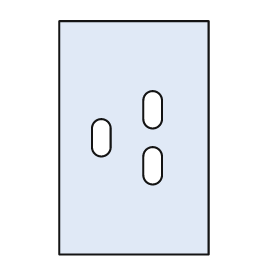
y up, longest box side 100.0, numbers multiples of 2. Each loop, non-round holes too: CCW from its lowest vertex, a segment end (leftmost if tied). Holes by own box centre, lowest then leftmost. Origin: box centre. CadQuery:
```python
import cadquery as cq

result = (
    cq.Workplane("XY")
    .moveTo(-32.0, -50.0)
    .lineTo(32.0, -50.0)
    .lineTo(32.0, 50.0)
    .lineTo(-32.0, 50.0)
    .close()
    .moveTo(4.0, -16.0)
    .threePointArc((8.0, -20.0), (12.0, -16.0))
    .lineTo(12.0, -8.0)
    .threePointArc((8.0, -4.0), (4.0, -8.0))
    .close()
    .moveTo(-18.0, -4.0)
    .threePointArc((-14.0, -8.0), (-10.0, -4.0))
    .lineTo(-10.0, 4.0)
    .threePointArc((-14.0, 8.0), (-18.0, 4.0))
    .close()
    .moveTo(4.0, 8.0)
    .threePointArc((8.0, 4.0), (12.0, 8.0))
    .lineTo(12.0, 16.0)
    .threePointArc((8.0, 20.0), (4.0, 16.0))
    .close()
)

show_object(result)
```